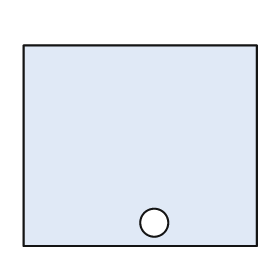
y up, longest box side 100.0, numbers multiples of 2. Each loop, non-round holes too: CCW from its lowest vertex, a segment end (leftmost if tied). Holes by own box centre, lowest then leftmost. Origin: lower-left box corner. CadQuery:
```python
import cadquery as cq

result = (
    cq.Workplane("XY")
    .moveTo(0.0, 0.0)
    .lineTo(100.0, 0.0)
    .lineTo(100.0, 86.0)
    .lineTo(0.0, 86.0)
    .close()
    .moveTo(56.0, 10.0)
    .circle(6.0)
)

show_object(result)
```